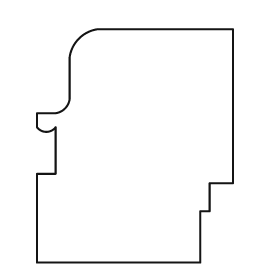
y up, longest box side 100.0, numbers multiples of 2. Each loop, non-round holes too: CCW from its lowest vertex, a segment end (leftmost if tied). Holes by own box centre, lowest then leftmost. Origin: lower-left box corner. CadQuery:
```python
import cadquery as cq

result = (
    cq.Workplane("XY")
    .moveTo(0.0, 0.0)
    .lineTo(70.0, 0.0)
    .lineTo(70.0, 22.0)
    .lineTo(74.0, 22.0)
    .lineTo(74.0, 34.0)
    .lineTo(84.0, 34.0)
    .lineTo(84.0, 100.0)
    .lineTo(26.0, 100.0)
    .threePointArc((18.0, 96.0), (14.0, 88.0))
    .lineTo(14.0, 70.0)
    .threePointArc((12.0, 66.0), (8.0, 64.0))
    .lineTo(0.0, 64.0)
    .lineTo(0.0, 58.0)
    .threePointArc((4.0, 56.0), (8.0, 58.0))
    .lineTo(8.0, 38.0)
    .lineTo(0.0, 38.0)
    .close()
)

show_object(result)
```